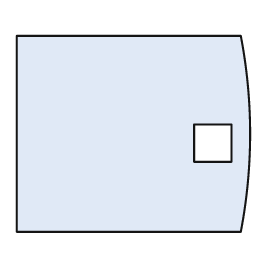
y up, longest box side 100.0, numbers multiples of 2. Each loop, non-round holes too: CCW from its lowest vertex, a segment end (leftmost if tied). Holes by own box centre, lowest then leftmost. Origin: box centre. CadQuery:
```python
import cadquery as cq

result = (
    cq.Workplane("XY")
    .moveTo(-50.0, -42.0)
    .lineTo(46.0, -42.0)
    .threePointArc((50.0, 0.0), (46.0, 42.0))
    .lineTo(-50.0, 42.0)
    .close()
    .moveTo(26.0, -12.0)
    .lineTo(42.0, -12.0)
    .lineTo(42.0, 4.0)
    .lineTo(26.0, 4.0)
    .close()
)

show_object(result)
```